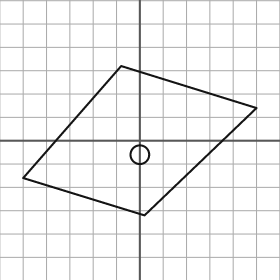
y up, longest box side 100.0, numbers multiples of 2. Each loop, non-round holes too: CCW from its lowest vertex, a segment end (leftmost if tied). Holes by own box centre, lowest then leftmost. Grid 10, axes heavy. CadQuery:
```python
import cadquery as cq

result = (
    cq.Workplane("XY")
    .moveTo(2.0, -32.0)
    .lineTo(50.0, 14.0)
    .lineTo(-8.0, 32.0)
    .lineTo(-50.0, -16.0)
    .close()
    .moveTo(0.0, -6.0)
    .circle(4.0)
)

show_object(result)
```